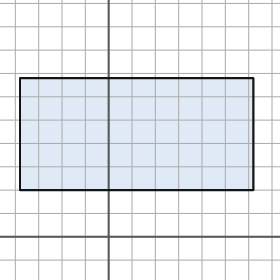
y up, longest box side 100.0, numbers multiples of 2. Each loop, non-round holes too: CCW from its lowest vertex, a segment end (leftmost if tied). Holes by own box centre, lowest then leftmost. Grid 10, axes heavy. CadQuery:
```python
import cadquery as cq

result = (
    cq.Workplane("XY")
    .moveTo(-38.0, 20.0)
    .lineTo(62.0, 20.0)
    .lineTo(62.0, 68.0)
    .lineTo(-38.0, 68.0)
    .close()
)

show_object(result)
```